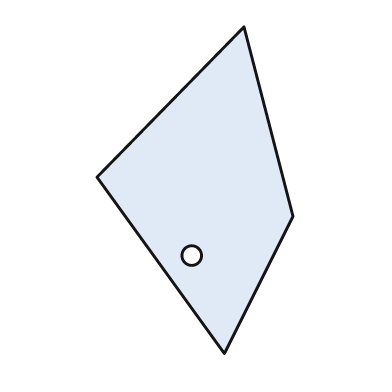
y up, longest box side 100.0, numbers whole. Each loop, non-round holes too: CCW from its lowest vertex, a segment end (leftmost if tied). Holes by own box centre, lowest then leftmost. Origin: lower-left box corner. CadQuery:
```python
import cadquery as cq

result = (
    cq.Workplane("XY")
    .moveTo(39.0, 0.0)
    .lineTo(60.0, 42.0)
    .lineTo(45.0, 100.0)
    .lineTo(0.0, 54.0)
    .close()
    .moveTo(29.0, 30.0)
    .circle(3.0)
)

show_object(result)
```